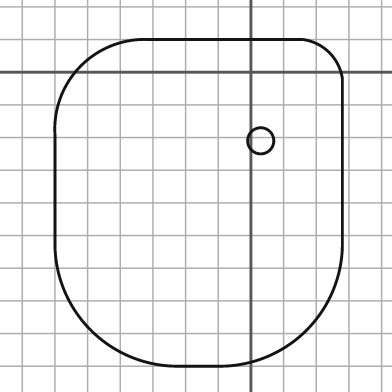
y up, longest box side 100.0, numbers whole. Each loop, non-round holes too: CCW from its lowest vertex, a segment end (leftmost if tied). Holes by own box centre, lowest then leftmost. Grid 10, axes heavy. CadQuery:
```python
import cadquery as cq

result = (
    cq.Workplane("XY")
    .moveTo(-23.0, -90.0)
    .lineTo(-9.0, -90.0)
    .threePointArc((17.0, -79.0), (28.0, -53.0))
    .lineTo(28.0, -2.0)
    .threePointArc((24.0, 6.0), (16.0, 10.0))
    .lineTo(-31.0, 10.0)
    .threePointArc((-52.0, 2.0), (-60.0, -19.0))
    .lineTo(-60.0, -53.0)
    .threePointArc((-49.0, -79.0), (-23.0, -90.0))
    .close()
    .moveTo(3.0, -21.0)
    .circle(4.0)
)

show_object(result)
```